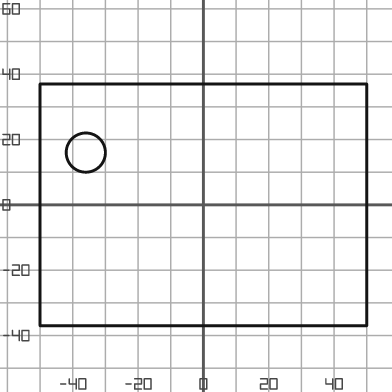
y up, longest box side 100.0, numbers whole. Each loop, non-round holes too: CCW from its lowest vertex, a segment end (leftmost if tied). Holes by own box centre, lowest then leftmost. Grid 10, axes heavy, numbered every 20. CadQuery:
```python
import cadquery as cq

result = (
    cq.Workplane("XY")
    .moveTo(-50.0, -37.0)
    .lineTo(50.0, -37.0)
    .lineTo(50.0, 37.0)
    .lineTo(-50.0, 37.0)
    .close()
    .moveTo(-36.0, 16.0)
    .circle(6.0)
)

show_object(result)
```